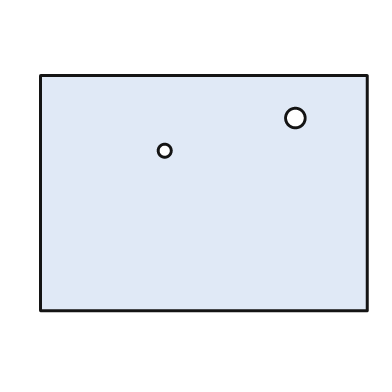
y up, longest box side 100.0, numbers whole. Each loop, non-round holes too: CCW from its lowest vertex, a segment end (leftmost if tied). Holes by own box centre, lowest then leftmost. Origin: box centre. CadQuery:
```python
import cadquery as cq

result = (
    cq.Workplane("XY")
    .moveTo(-50.0, -36.0)
    .lineTo(50.0, -36.0)
    .lineTo(50.0, 36.0)
    .lineTo(-50.0, 36.0)
    .close()
    .moveTo(-12.0, 13.0)
    .circle(2.0)
    .moveTo(28.0, 23.0)
    .circle(3.0)
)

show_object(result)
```